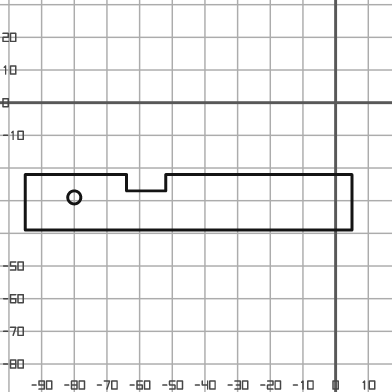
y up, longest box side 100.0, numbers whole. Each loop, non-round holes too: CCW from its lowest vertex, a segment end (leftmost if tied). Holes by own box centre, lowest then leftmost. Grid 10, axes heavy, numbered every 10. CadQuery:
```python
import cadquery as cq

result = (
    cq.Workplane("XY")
    .moveTo(-95.0, -39.0)
    .lineTo(5.0, -39.0)
    .lineTo(5.0, -22.0)
    .lineTo(-52.0, -22.0)
    .lineTo(-52.0, -27.0)
    .lineTo(-64.0, -27.0)
    .lineTo(-64.0, -22.0)
    .lineTo(-95.0, -22.0)
    .close()
    .moveTo(-80.0, -29.0)
    .circle(2.0)
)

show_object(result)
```